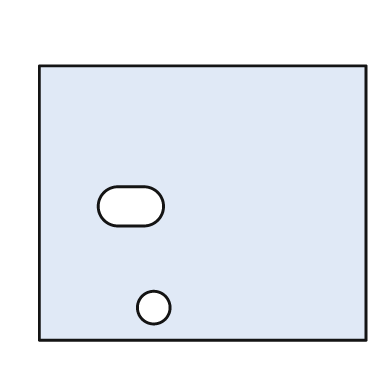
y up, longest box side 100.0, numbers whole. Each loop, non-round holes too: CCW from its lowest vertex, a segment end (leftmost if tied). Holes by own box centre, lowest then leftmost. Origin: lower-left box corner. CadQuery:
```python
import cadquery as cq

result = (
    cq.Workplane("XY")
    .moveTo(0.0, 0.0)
    .lineTo(100.0, 0.0)
    .lineTo(100.0, 84.0)
    .lineTo(0.0, 84.0)
    .close()
    .moveTo(35.0, 10.0)
    .circle(5.0)
    .moveTo(24.0, 35.0)
    .lineTo(32.0, 35.0)
    .threePointArc((38.0, 41.0), (32.0, 47.0))
    .lineTo(24.0, 47.0)
    .threePointArc((18.0, 41.0), (24.0, 35.0))
    .close()
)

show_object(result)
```